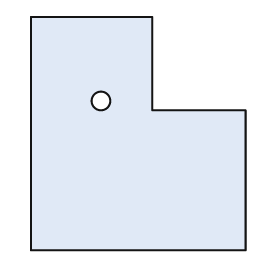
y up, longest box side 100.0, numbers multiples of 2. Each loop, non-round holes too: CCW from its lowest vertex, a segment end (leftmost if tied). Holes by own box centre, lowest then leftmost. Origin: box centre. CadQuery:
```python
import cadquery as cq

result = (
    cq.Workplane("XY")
    .moveTo(-46.0, -50.0)
    .lineTo(46.0, -50.0)
    .lineTo(46.0, 10.0)
    .lineTo(6.0, 10.0)
    .lineTo(6.0, 50.0)
    .lineTo(-46.0, 50.0)
    .close()
    .moveTo(-16.0, 14.0)
    .circle(4.0)
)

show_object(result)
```